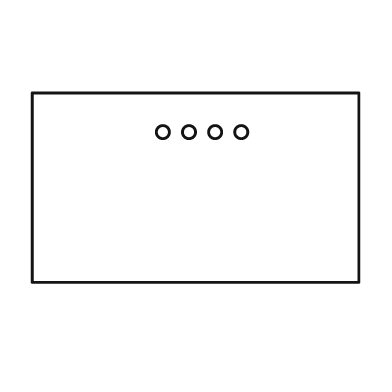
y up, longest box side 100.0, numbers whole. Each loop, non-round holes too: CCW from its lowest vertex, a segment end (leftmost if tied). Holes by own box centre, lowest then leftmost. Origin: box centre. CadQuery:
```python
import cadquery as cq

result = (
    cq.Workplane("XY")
    .moveTo(-50.0, -29.0)
    .lineTo(50.0, -29.0)
    .lineTo(50.0, 29.0)
    .lineTo(-50.0, 29.0)
    .close()
    .moveTo(-10.0, 17.0)
    .circle(2.0)
    .moveTo(-2.0, 17.0)
    .circle(2.0)
    .moveTo(6.0, 17.0)
    .circle(2.0)
    .moveTo(14.0, 17.0)
    .circle(2.0)
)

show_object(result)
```